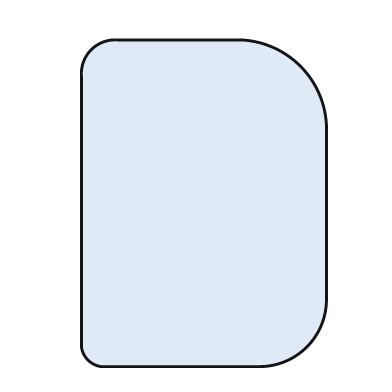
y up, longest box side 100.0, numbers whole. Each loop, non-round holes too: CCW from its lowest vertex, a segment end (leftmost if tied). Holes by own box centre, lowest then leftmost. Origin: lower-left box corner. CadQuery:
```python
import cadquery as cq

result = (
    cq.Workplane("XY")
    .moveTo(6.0, 0.0)
    .lineTo(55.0, 0.0)
    .threePointArc((69.0, 6.0), (75.0, 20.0))
    .lineTo(75.0, 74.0)
    .threePointArc((67.0, 92.0), (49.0, 100.0))
    .lineTo(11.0, 100.0)
    .threePointArc((3.0, 97.0), (0.0, 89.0))
    .lineTo(0.0, 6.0)
    .threePointArc((2.0, 2.0), (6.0, 0.0))
    .close()
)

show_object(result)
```